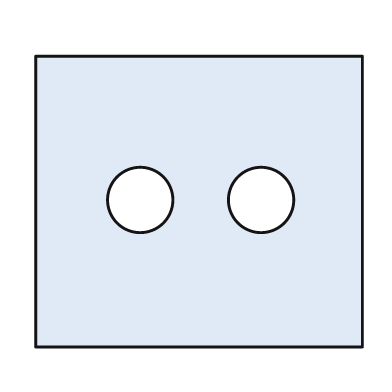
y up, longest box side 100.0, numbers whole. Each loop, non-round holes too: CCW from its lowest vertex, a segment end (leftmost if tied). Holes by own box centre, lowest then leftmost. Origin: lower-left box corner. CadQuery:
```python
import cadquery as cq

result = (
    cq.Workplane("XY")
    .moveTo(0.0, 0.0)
    .lineTo(100.0, 0.0)
    .lineTo(100.0, 89.0)
    .lineTo(0.0, 89.0)
    .close()
    .moveTo(32.0, 45.0)
    .circle(10.0)
    .moveTo(69.0, 45.0)
    .circle(10.0)
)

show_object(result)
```